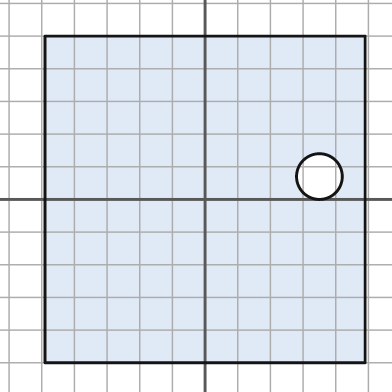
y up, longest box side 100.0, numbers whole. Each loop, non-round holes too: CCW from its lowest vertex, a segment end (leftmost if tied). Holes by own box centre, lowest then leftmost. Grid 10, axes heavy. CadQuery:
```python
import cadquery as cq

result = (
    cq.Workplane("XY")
    .moveTo(-49.0, -50.0)
    .lineTo(49.0, -50.0)
    .lineTo(49.0, 50.0)
    .lineTo(-49.0, 50.0)
    .close()
    .moveTo(35.0, 7.0)
    .circle(7.0)
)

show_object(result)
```